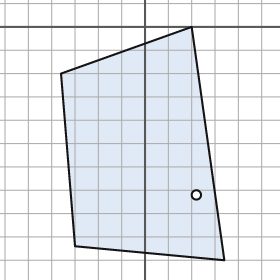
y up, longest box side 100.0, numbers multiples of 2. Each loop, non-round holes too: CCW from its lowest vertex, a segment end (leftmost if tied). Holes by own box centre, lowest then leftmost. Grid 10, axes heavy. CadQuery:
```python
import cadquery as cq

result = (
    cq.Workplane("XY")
    .moveTo(34.0, -100.0)
    .lineTo(20.0, 0.0)
    .lineTo(-36.0, -20.0)
    .lineTo(-30.0, -94.0)
    .close()
    .moveTo(22.0, -72.0)
    .circle(2.0)
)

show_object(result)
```